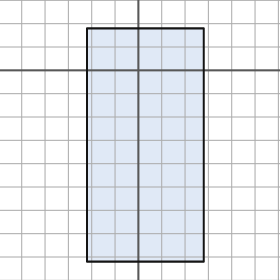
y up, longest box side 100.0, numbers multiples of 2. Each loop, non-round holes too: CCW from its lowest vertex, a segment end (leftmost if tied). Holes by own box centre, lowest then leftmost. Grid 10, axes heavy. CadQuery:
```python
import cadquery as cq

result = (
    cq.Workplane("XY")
    .moveTo(-22.0, -82.0)
    .lineTo(28.0, -82.0)
    .lineTo(28.0, 18.0)
    .lineTo(-22.0, 18.0)
    .close()
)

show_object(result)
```